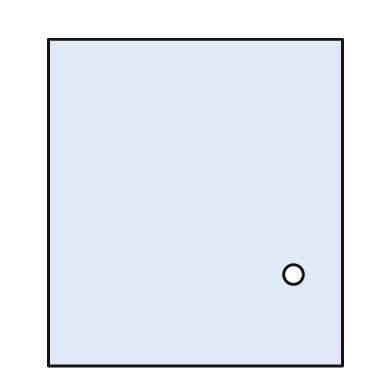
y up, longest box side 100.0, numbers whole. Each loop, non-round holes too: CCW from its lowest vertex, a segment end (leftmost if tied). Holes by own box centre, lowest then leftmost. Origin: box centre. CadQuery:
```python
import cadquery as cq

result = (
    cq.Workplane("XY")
    .moveTo(-45.0, -50.0)
    .lineTo(45.0, -50.0)
    .lineTo(45.0, 50.0)
    .lineTo(-45.0, 50.0)
    .close()
    .moveTo(30.0, -22.0)
    .circle(3.0)
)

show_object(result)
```